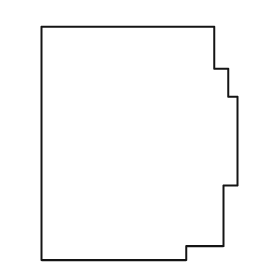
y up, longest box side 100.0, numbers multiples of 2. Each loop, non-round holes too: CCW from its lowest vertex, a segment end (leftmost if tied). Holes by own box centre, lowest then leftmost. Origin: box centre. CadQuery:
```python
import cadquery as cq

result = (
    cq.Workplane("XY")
    .moveTo(-42.0, -50.0)
    .lineTo(20.0, -50.0)
    .lineTo(20.0, -44.0)
    .lineTo(36.0, -44.0)
    .lineTo(36.0, -18.0)
    .lineTo(42.0, -18.0)
    .lineTo(42.0, 20.0)
    .lineTo(38.0, 20.0)
    .lineTo(38.0, 32.0)
    .lineTo(32.0, 32.0)
    .lineTo(32.0, 50.0)
    .lineTo(-42.0, 50.0)
    .close()
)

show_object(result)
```